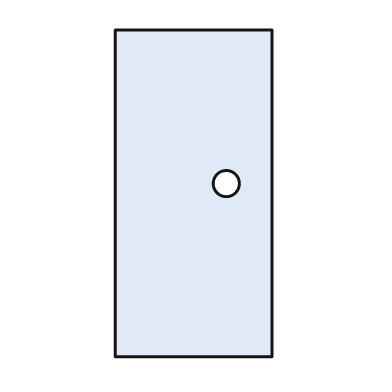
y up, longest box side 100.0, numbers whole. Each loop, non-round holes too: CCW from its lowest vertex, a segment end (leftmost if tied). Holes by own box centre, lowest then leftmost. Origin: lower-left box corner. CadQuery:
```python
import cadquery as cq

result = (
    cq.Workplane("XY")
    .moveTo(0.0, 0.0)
    .lineTo(48.0, 0.0)
    .lineTo(48.0, 100.0)
    .lineTo(0.0, 100.0)
    .close()
    .moveTo(34.0, 53.0)
    .circle(4.0)
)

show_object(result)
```